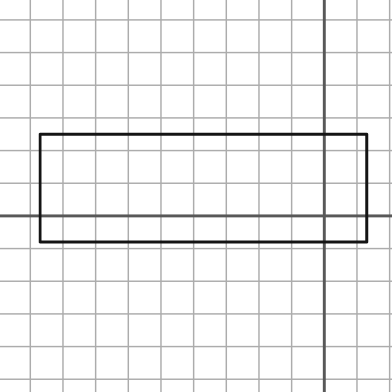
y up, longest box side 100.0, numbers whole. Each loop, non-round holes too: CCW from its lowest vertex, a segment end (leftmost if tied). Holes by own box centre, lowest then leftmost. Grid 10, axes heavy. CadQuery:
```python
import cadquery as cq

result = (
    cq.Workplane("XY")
    .moveTo(-87.0, -8.0)
    .lineTo(13.0, -8.0)
    .lineTo(13.0, 25.0)
    .lineTo(-87.0, 25.0)
    .close()
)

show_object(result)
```